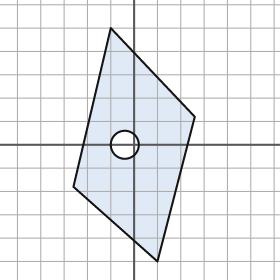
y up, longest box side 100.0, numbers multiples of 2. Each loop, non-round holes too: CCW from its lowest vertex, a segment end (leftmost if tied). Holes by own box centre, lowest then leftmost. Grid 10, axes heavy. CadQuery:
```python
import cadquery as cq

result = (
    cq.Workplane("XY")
    .moveTo(10.0, -50.0)
    .lineTo(26.0, 12.0)
    .lineTo(-10.0, 50.0)
    .lineTo(-26.0, -18.0)
    .close()
    .moveTo(-4.0, 0.0)
    .circle(6.0)
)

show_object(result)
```